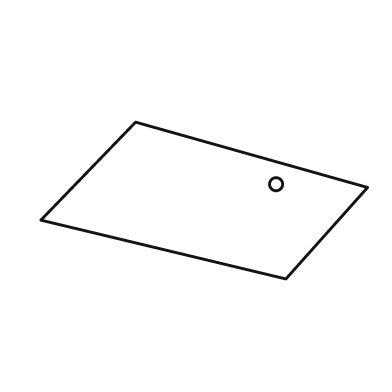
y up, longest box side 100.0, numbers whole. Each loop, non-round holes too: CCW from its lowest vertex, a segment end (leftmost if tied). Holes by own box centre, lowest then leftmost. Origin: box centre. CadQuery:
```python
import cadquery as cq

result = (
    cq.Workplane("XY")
    .moveTo(25.0, -24.0)
    .lineTo(50.0, 4.0)
    .lineTo(-21.0, 24.0)
    .lineTo(-50.0, -6.0)
    .close()
    .moveTo(22.0, 5.0)
    .circle(2.0)
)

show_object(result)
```